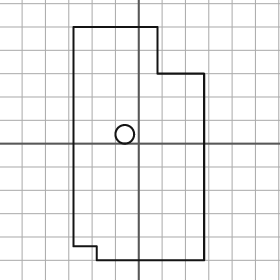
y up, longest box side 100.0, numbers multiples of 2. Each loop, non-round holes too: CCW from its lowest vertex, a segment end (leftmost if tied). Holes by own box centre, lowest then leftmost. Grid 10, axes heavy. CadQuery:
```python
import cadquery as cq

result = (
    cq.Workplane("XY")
    .moveTo(-18.0, -50.0)
    .lineTo(28.0, -50.0)
    .lineTo(28.0, 30.0)
    .lineTo(8.0, 30.0)
    .lineTo(8.0, 50.0)
    .lineTo(-28.0, 50.0)
    .lineTo(-28.0, -44.0)
    .lineTo(-18.0, -44.0)
    .close()
    .moveTo(-6.0, 4.0)
    .circle(4.0)
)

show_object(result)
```